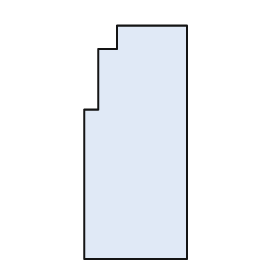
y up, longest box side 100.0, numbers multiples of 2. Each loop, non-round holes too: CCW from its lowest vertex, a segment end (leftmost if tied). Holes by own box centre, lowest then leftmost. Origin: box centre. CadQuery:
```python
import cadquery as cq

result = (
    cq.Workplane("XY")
    .moveTo(-22.0, -50.0)
    .lineTo(22.0, -50.0)
    .lineTo(22.0, 50.0)
    .lineTo(-8.0, 50.0)
    .lineTo(-8.0, 40.0)
    .lineTo(-16.0, 40.0)
    .lineTo(-16.0, 14.0)
    .lineTo(-22.0, 14.0)
    .close()
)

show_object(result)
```